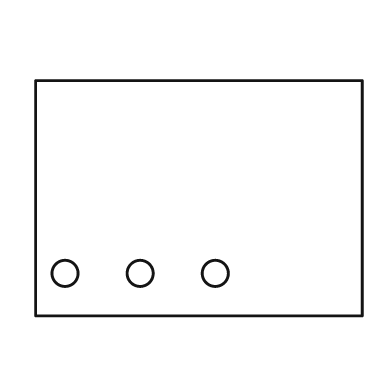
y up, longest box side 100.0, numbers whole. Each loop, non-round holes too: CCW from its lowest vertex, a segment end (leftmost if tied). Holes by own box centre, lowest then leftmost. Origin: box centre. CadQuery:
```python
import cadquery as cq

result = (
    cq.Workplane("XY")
    .moveTo(-50.0, -36.0)
    .lineTo(50.0, -36.0)
    .lineTo(50.0, 36.0)
    .lineTo(-50.0, 36.0)
    .close()
    .moveTo(-41.0, -23.0)
    .circle(4.0)
    .moveTo(-18.0, -23.0)
    .circle(4.0)
    .moveTo(5.0, -23.0)
    .circle(4.0)
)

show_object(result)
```